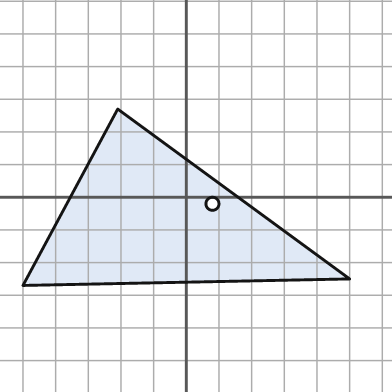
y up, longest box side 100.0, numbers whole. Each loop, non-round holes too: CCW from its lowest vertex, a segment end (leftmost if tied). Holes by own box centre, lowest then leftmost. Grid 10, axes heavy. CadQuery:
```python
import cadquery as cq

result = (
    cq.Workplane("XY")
    .moveTo(-50.0, -27.0)
    .lineTo(50.0, -25.0)
    .lineTo(-21.0, 27.0)
    .close()
    .moveTo(8.0, -2.0)
    .circle(2.0)
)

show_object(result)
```